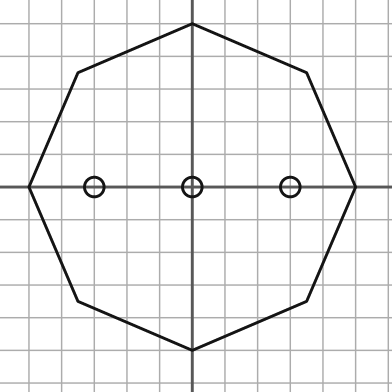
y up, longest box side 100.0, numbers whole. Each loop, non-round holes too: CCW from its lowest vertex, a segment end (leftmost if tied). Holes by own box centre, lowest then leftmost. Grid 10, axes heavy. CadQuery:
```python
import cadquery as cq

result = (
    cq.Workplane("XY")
    .moveTo(0.0, -50.0)
    .lineTo(35.0, -35.0)
    .lineTo(50.0, 0.0)
    .lineTo(35.0, 35.0)
    .lineTo(0.0, 50.0)
    .lineTo(-35.0, 35.0)
    .lineTo(-50.0, 0.0)
    .lineTo(-35.0, -35.0)
    .close()
    .moveTo(-30.0, 0.0)
    .circle(3.0)
    .moveTo(0.0, 0.0)
    .circle(3.0)
    .moveTo(30.0, 0.0)
    .circle(3.0)
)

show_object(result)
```